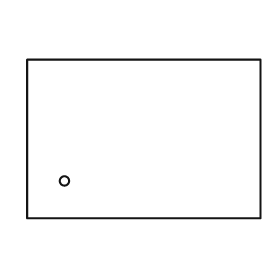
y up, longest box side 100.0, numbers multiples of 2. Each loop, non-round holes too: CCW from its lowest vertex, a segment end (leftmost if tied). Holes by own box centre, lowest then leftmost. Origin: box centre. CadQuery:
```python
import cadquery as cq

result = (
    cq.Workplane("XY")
    .moveTo(-50.0, -34.0)
    .lineTo(50.0, -34.0)
    .lineTo(50.0, 34.0)
    .lineTo(-50.0, 34.0)
    .close()
    .moveTo(-34.0, -18.0)
    .circle(2.0)
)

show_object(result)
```